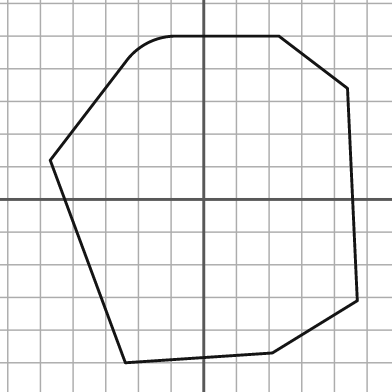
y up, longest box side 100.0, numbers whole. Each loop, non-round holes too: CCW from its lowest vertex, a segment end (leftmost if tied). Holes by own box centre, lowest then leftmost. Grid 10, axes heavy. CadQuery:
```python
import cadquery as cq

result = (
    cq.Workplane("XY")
    .moveTo(-24.0, -50.0)
    .lineTo(21.0, -47.0)
    .lineTo(47.0, -31.0)
    .lineTo(44.0, 34.0)
    .lineTo(23.0, 50.0)
    .lineTo(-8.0, 50.0)
    .threePointArc((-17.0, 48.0), (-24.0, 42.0))
    .lineTo(-47.0, 12.0)
    .close()
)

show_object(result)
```